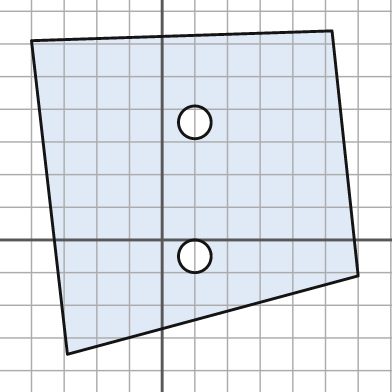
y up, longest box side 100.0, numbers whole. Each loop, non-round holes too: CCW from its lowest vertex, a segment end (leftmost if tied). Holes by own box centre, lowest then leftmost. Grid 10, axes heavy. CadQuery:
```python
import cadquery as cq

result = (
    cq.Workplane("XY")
    .moveTo(-29.0, -35.0)
    .lineTo(60.0, -11.0)
    .lineTo(52.0, 64.0)
    .lineTo(-40.0, 61.0)
    .close()
    .moveTo(10.0, -5.0)
    .circle(5.0)
    .moveTo(10.0, 36.0)
    .circle(5.0)
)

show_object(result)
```